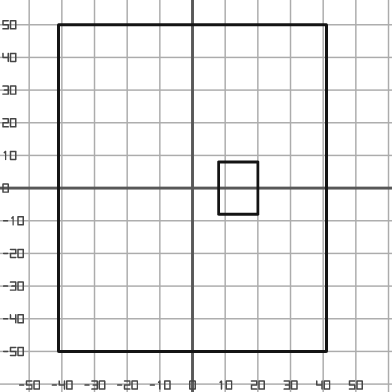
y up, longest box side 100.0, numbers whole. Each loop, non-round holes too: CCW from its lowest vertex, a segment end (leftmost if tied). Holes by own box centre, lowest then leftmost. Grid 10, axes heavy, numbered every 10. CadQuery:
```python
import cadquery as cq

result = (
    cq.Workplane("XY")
    .moveTo(-41.0, -50.0)
    .lineTo(41.0, -50.0)
    .lineTo(41.0, 50.0)
    .lineTo(-41.0, 50.0)
    .close()
    .moveTo(8.0, -8.0)
    .lineTo(20.0, -8.0)
    .lineTo(20.0, 8.0)
    .lineTo(8.0, 8.0)
    .close()
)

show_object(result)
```